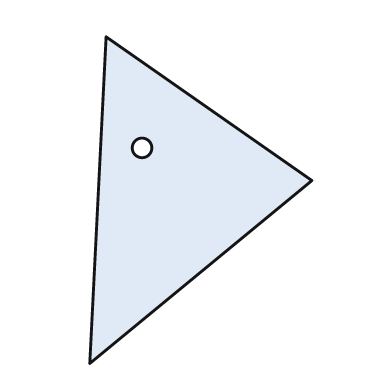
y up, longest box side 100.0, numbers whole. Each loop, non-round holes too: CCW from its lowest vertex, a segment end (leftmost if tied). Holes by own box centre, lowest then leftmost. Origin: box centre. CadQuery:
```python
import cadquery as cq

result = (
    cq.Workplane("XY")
    .moveTo(-34.0, -50.0)
    .lineTo(34.0, 6.0)
    .lineTo(-29.0, 50.0)
    .close()
    .moveTo(-18.0, 16.0)
    .circle(3.0)
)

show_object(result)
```